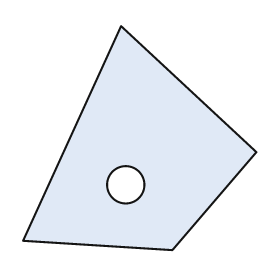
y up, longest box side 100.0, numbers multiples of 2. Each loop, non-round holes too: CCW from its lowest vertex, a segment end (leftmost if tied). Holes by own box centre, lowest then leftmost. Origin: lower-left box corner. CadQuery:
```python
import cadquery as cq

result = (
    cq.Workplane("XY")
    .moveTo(64.0, 0.0)
    .lineTo(100.0, 42.0)
    .lineTo(42.0, 96.0)
    .lineTo(0.0, 4.0)
    .close()
    .moveTo(44.0, 28.0)
    .circle(8.0)
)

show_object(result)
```